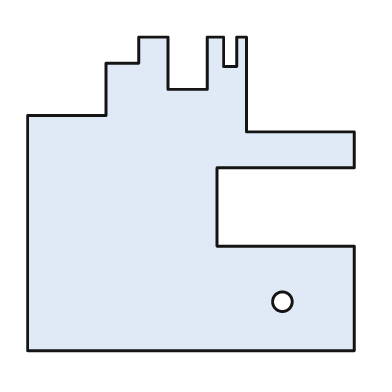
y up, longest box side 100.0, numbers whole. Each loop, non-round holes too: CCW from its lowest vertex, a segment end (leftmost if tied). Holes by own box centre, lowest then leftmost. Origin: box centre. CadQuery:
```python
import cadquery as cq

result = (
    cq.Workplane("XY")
    .moveTo(-50.0, -48.0)
    .lineTo(50.0, -48.0)
    .lineTo(50.0, -16.0)
    .lineTo(8.0, -16.0)
    .lineTo(8.0, 8.0)
    .lineTo(50.0, 8.0)
    .lineTo(50.0, 19.0)
    .lineTo(17.0, 19.0)
    .lineTo(17.0, 48.0)
    .lineTo(14.0, 48.0)
    .lineTo(14.0, 39.0)
    .lineTo(10.0, 39.0)
    .lineTo(10.0, 48.0)
    .lineTo(5.0, 48.0)
    .lineTo(5.0, 32.0)
    .lineTo(-7.0, 32.0)
    .lineTo(-7.0, 48.0)
    .lineTo(-16.0, 48.0)
    .lineTo(-16.0, 40.0)
    .lineTo(-26.0, 40.0)
    .lineTo(-26.0, 24.0)
    .lineTo(-50.0, 24.0)
    .close()
    .moveTo(28.0, -33.0)
    .circle(3.0)
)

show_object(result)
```